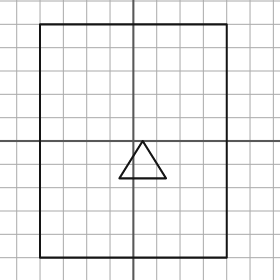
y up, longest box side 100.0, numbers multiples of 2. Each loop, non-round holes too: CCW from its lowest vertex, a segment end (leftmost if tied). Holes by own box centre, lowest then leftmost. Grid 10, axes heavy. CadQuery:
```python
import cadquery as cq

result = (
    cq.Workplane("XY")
    .moveTo(-40.0, -50.0)
    .lineTo(40.0, -50.0)
    .lineTo(40.0, 50.0)
    .lineTo(-40.0, 50.0)
    .close()
    .moveTo(-6.0, -16.0)
    .lineTo(14.0, -16.0)
    .lineTo(4.0, 0.0)
    .close()
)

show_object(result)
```